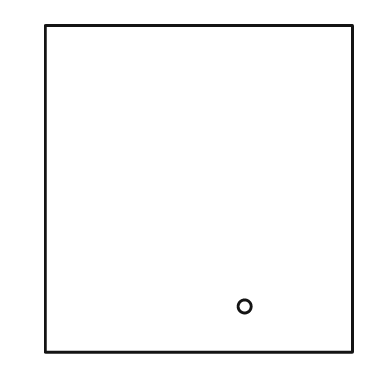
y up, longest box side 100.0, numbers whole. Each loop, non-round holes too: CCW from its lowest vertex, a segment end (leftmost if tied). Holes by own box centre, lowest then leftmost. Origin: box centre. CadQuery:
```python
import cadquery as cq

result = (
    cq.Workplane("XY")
    .moveTo(-47.0, -50.0)
    .lineTo(47.0, -50.0)
    .lineTo(47.0, 50.0)
    .lineTo(-47.0, 50.0)
    .close()
    .moveTo(14.0, -36.0)
    .circle(2.0)
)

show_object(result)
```